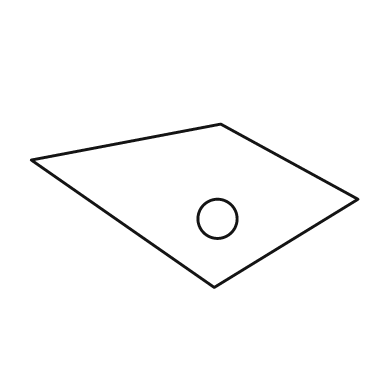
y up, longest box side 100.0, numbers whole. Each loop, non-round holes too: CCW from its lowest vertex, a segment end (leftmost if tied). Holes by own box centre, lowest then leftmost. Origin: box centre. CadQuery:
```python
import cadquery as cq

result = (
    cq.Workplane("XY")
    .moveTo(6.0, -25.0)
    .lineTo(50.0, 2.0)
    .lineTo(8.0, 25.0)
    .lineTo(-50.0, 14.0)
    .close()
    .moveTo(7.0, -4.0)
    .circle(6.0)
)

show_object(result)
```